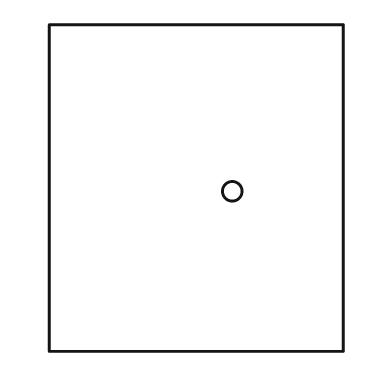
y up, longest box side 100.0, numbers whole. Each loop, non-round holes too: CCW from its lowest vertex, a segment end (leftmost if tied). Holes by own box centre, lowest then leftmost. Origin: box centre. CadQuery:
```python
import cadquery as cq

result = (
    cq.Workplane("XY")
    .moveTo(-45.0, -50.0)
    .lineTo(45.0, -50.0)
    .lineTo(45.0, 50.0)
    .lineTo(-45.0, 50.0)
    .close()
    .moveTo(11.0, -1.0)
    .circle(3.0)
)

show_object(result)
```